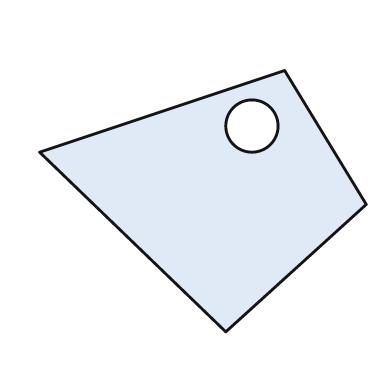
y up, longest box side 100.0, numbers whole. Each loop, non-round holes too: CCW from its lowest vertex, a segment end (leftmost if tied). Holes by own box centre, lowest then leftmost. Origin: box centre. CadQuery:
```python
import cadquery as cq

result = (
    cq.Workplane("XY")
    .moveTo(7.0, -40.0)
    .lineTo(50.0, -1.0)
    .lineTo(25.0, 40.0)
    .lineTo(-50.0, 15.0)
    .close()
    .moveTo(15.0, 23.0)
    .circle(8.0)
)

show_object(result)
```